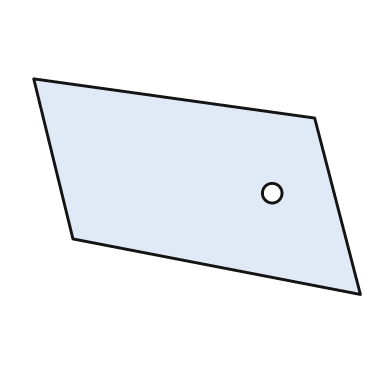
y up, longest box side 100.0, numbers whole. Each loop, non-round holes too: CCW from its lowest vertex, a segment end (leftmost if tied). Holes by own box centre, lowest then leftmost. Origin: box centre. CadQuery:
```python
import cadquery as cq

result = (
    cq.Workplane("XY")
    .moveTo(50.0, -33.0)
    .lineTo(36.0, 21.0)
    .lineTo(-50.0, 33.0)
    .lineTo(-38.0, -16.0)
    .close()
    .moveTo(23.0, -2.0)
    .circle(3.0)
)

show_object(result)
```